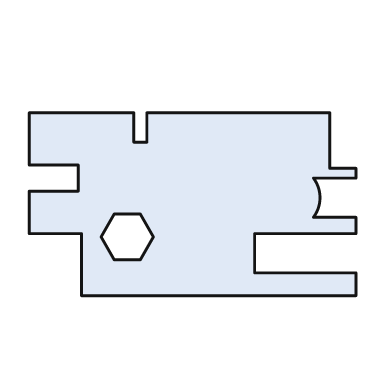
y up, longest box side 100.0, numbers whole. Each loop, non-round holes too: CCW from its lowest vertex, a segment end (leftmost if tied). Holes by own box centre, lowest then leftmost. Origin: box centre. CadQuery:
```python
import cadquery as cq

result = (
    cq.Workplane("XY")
    .moveTo(-34.0, -28.0)
    .lineTo(50.0, -28.0)
    .lineTo(50.0, -21.0)
    .lineTo(19.0, -21.0)
    .lineTo(19.0, -9.0)
    .lineTo(50.0, -9.0)
    .lineTo(50.0, -4.0)
    .lineTo(37.0, -4.0)
    .threePointArc((39.0, 2.0), (37.0, 8.0))
    .lineTo(50.0, 8.0)
    .lineTo(50.0, 11.0)
    .lineTo(42.0, 11.0)
    .lineTo(42.0, 28.0)
    .lineTo(-14.0, 28.0)
    .lineTo(-14.0, 19.0)
    .lineTo(-18.0, 19.0)
    .lineTo(-18.0, 28.0)
    .lineTo(-50.0, 28.0)
    .lineTo(-50.0, 12.0)
    .lineTo(-35.0, 12.0)
    .lineTo(-35.0, 4.0)
    .lineTo(-50.0, 4.0)
    .lineTo(-50.0, -9.0)
    .lineTo(-34.0, -9.0)
    .close()
    .moveTo(-24.0, -17.0)
    .lineTo(-16.0, -17.0)
    .lineTo(-12.0, -10.0)
    .lineTo(-16.0, -3.0)
    .lineTo(-24.0, -3.0)
    .lineTo(-28.0, -10.0)
    .close()
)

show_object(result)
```